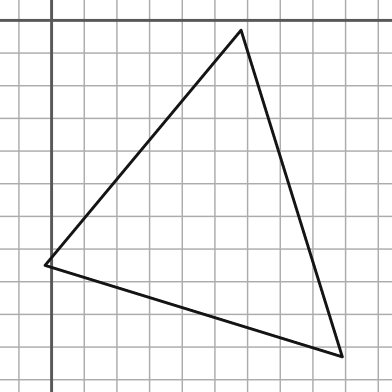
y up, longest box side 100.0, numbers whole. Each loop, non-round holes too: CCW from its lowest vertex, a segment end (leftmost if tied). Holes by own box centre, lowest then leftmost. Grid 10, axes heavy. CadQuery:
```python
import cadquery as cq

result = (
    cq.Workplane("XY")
    .moveTo(89.0, -103.0)
    .lineTo(58.0, -3.0)
    .lineTo(-2.0, -75.0)
    .close()
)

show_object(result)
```